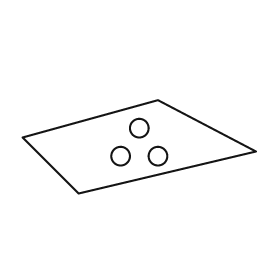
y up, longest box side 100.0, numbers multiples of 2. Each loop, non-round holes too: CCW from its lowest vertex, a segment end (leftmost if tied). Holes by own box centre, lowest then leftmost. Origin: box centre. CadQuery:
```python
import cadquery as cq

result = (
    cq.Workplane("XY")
    .moveTo(-26.0, -20.0)
    .lineTo(50.0, -2.0)
    .lineTo(8.0, 20.0)
    .lineTo(-50.0, 4.0)
    .close()
    .moveTo(-8.0, -4.0)
    .circle(4.0)
    .moveTo(8.0, -4.0)
    .circle(4.0)
    .moveTo(0.0, 8.0)
    .circle(4.0)
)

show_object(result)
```